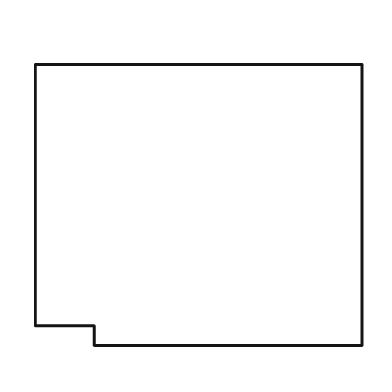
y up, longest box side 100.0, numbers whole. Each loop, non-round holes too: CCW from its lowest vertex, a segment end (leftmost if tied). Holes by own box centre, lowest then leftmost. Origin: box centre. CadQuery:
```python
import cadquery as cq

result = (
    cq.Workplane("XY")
    .moveTo(-32.0, -43.0)
    .lineTo(50.0, -43.0)
    .lineTo(50.0, 43.0)
    .lineTo(-50.0, 43.0)
    .lineTo(-50.0, -37.0)
    .lineTo(-32.0, -37.0)
    .close()
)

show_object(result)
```